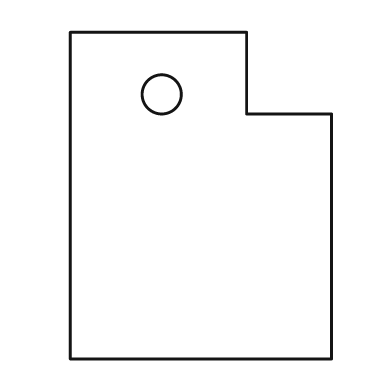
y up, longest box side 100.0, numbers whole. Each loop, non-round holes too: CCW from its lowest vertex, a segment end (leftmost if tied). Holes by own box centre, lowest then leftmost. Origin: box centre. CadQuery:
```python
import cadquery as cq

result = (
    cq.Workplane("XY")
    .moveTo(-40.0, -50.0)
    .lineTo(40.0, -50.0)
    .lineTo(40.0, 25.0)
    .lineTo(14.0, 25.0)
    .lineTo(14.0, 50.0)
    .lineTo(-40.0, 50.0)
    .close()
    .moveTo(-12.0, 31.0)
    .circle(6.0)
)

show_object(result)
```